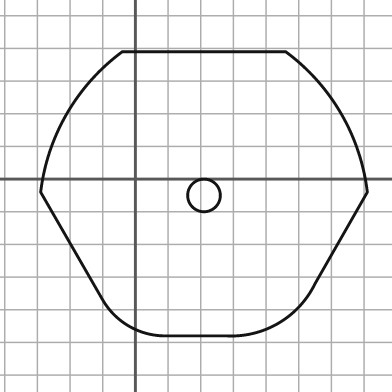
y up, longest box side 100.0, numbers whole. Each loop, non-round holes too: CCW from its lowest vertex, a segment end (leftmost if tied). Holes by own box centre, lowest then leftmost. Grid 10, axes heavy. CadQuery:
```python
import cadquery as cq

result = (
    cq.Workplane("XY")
    .moveTo(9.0, -48.0)
    .lineTo(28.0, -48.0)
    .threePointArc((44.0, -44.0), (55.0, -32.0))
    .lineTo(71.0, -4.0)
    .threePointArc((63.0, 20.0), (46.0, 39.0))
    .lineTo(-4.0, 39.0)
    .threePointArc((-21.0, 20.0), (-29.0, -4.0))
    .lineTo(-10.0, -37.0)
    .threePointArc((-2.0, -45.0), (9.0, -48.0))
    .close()
    .moveTo(21.0, -5.0)
    .circle(5.0)
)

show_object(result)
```